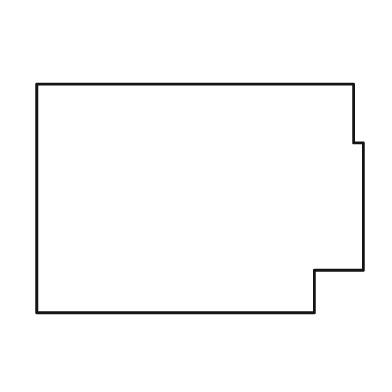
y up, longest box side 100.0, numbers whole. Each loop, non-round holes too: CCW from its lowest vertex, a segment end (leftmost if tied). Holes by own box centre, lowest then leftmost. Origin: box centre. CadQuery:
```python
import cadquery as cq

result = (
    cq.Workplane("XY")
    .moveTo(-50.0, -35.0)
    .lineTo(35.0, -35.0)
    .lineTo(35.0, -22.0)
    .lineTo(50.0, -22.0)
    .lineTo(50.0, 17.0)
    .lineTo(47.0, 17.0)
    .lineTo(47.0, 35.0)
    .lineTo(-50.0, 35.0)
    .close()
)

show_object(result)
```